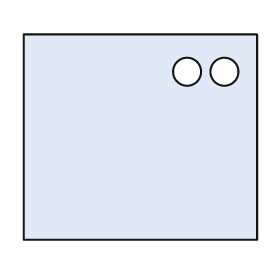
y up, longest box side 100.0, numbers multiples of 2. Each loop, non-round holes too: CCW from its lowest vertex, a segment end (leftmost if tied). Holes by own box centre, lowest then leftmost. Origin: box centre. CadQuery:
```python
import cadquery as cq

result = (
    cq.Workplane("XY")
    .moveTo(-50.0, -44.0)
    .lineTo(50.0, -44.0)
    .lineTo(50.0, 44.0)
    .lineTo(-50.0, 44.0)
    .close()
    .moveTo(20.0, 28.0)
    .circle(6.0)
    .moveTo(36.0, 28.0)
    .circle(6.0)
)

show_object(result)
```